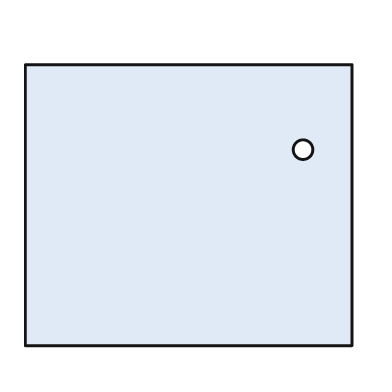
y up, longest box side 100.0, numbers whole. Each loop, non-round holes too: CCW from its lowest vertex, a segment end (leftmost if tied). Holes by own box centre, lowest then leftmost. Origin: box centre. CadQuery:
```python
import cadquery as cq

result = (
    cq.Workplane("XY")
    .moveTo(-50.0, -43.0)
    .lineTo(50.0, -43.0)
    .lineTo(50.0, 43.0)
    .lineTo(-50.0, 43.0)
    .close()
    .moveTo(35.0, 17.0)
    .circle(3.0)
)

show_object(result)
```